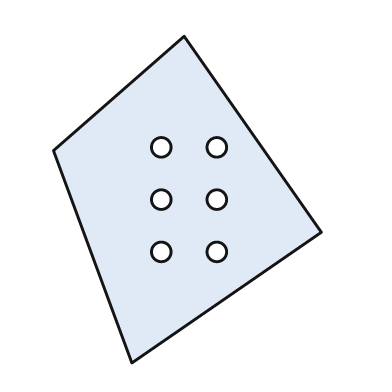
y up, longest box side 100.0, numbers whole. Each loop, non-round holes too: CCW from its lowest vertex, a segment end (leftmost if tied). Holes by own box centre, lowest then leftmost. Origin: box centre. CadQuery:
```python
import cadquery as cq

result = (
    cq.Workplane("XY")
    .moveTo(-17.0, -50.0)
    .lineTo(41.0, -10.0)
    .lineTo(-1.0, 50.0)
    .lineTo(-41.0, 15.0)
    .close()
    .moveTo(-8.0, -16.0)
    .circle(3.0)
    .moveTo(9.0, -16.0)
    .circle(3.0)
    .moveTo(-8.0, 0.0)
    .circle(3.0)
    .moveTo(9.0, 0.0)
    .circle(3.0)
    .moveTo(-8.0, 16.0)
    .circle(3.0)
    .moveTo(9.0, 16.0)
    .circle(3.0)
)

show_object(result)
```